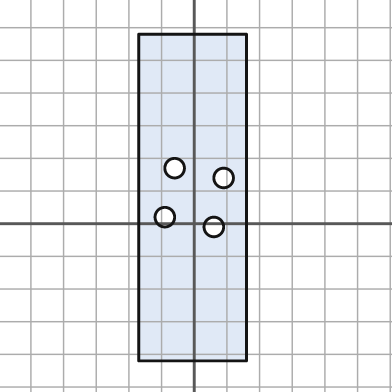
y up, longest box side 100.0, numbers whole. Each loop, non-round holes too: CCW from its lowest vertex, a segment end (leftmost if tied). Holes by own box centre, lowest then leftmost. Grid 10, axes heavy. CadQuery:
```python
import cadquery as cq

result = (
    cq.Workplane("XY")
    .moveTo(-17.0, -42.0)
    .lineTo(16.0, -42.0)
    .lineTo(16.0, 58.0)
    .lineTo(-17.0, 58.0)
    .close()
    .moveTo(6.0, -1.0)
    .circle(3.0)
    .moveTo(-9.0, 2.0)
    .circle(3.0)
    .moveTo(9.0, 14.0)
    .circle(3.0)
    .moveTo(-6.0, 17.0)
    .circle(3.0)
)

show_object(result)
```